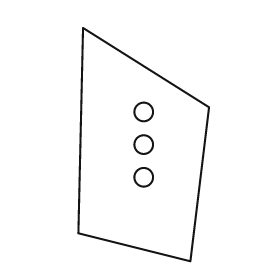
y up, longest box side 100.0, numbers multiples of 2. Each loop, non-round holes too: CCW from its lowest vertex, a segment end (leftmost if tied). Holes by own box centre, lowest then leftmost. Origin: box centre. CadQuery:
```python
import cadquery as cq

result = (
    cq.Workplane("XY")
    .moveTo(20.0, -50.0)
    .lineTo(28.0, 16.0)
    .lineTo(-26.0, 50.0)
    .lineTo(-28.0, -38.0)
    .close()
    .moveTo(0.0, -14.0)
    .circle(4.0)
    .moveTo(0.0, 0.0)
    .circle(4.0)
    .moveTo(0.0, 14.0)
    .circle(4.0)
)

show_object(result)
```